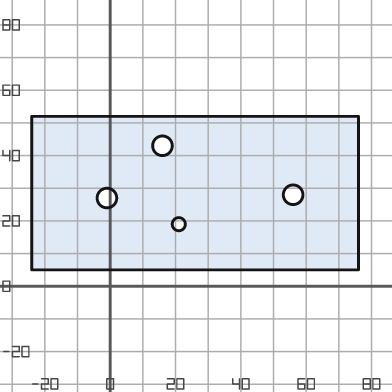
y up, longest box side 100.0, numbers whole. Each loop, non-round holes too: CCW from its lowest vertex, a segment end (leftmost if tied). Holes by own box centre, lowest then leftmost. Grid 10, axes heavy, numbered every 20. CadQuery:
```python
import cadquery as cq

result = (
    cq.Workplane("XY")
    .moveTo(-24.0, 5.0)
    .lineTo(76.0, 5.0)
    .lineTo(76.0, 52.0)
    .lineTo(-24.0, 52.0)
    .close()
    .moveTo(21.0, 19.0)
    .circle(2.0)
    .moveTo(-1.0, 27.0)
    .circle(3.0)
    .moveTo(56.0, 28.0)
    .circle(3.0)
    .moveTo(16.0, 43.0)
    .circle(3.0)
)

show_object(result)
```